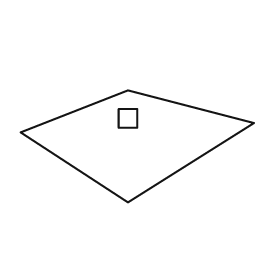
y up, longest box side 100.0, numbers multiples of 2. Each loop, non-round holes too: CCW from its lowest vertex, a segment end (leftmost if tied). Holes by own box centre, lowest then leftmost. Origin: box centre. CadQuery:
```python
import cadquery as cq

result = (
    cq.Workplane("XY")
    .moveTo(-4.0, -24.0)
    .lineTo(50.0, 10.0)
    .lineTo(-4.0, 24.0)
    .lineTo(-50.0, 6.0)
    .close()
    .moveTo(-8.0, 8.0)
    .lineTo(0.0, 8.0)
    .lineTo(0.0, 16.0)
    .lineTo(-8.0, 16.0)
    .close()
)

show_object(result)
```